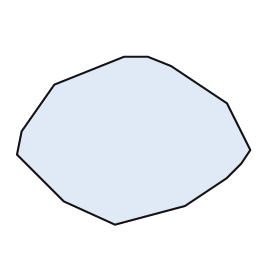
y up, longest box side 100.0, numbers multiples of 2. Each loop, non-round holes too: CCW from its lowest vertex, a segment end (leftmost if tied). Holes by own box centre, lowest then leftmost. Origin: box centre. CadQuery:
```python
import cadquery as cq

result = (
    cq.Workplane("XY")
    .moveTo(-8.0, -36.0)
    .lineTo(22.0, -28.0)
    .lineTo(40.0, -16.0)
    .lineTo(46.0, -10.0)
    .lineTo(50.0, -4.0)
    .lineTo(40.0, 16.0)
    .lineTo(16.0, 32.0)
    .lineTo(6.0, 36.0)
    .lineTo(-4.0, 36.0)
    .lineTo(-34.0, 24.0)
    .lineTo(-48.0, 4.0)
    .lineTo(-50.0, -6.0)
    .lineTo(-30.0, -26.0)
    .close()
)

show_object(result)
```